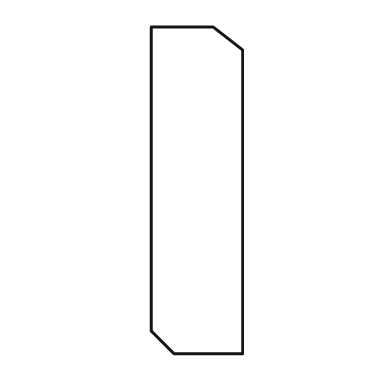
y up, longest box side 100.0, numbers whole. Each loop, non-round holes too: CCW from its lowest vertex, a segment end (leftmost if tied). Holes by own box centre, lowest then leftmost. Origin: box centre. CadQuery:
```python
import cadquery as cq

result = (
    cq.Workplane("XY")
    .moveTo(-7.0, -50.0)
    .lineTo(14.0, -50.0)
    .lineTo(14.0, 43.0)
    .lineTo(5.0, 50.0)
    .lineTo(-14.0, 50.0)
    .lineTo(-14.0, -43.0)
    .close()
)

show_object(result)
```